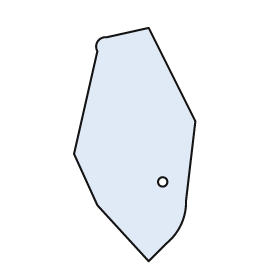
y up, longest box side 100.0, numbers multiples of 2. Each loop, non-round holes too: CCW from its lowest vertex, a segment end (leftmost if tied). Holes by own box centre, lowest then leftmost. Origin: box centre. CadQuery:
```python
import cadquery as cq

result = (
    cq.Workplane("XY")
    .moveTo(6.0, -50.0)
    .lineTo(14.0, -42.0)
    .threePointArc((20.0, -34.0), (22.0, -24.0))
    .lineTo(26.0, 10.0)
    .lineTo(6.0, 50.0)
    .lineTo(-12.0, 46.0)
    .threePointArc((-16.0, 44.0), (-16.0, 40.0))
    .lineTo(-26.0, -4.0)
    .lineTo(-16.0, -26.0)
    .close()
    .moveTo(12.0, -16.0)
    .circle(2.0)
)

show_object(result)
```